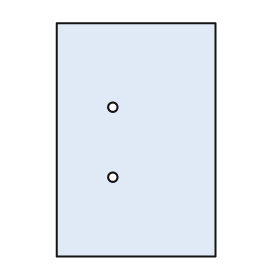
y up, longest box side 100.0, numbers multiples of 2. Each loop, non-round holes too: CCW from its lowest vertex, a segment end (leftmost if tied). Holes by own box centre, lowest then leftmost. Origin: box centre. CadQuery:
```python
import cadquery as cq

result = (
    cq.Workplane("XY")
    .moveTo(-34.0, -50.0)
    .lineTo(34.0, -50.0)
    .lineTo(34.0, 50.0)
    .lineTo(-34.0, 50.0)
    .close()
    .moveTo(-10.0, -16.0)
    .circle(2.0)
    .moveTo(-10.0, 14.0)
    .circle(2.0)
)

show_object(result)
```